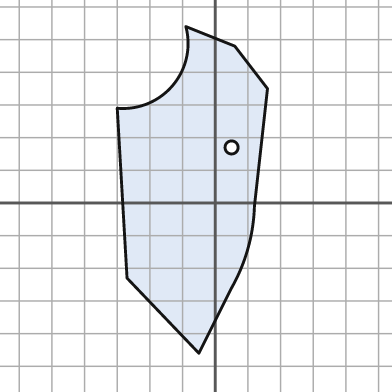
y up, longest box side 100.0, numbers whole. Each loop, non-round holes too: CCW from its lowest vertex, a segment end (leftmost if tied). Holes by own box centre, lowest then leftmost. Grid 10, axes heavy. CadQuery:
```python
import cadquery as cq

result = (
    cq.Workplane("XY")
    .moveTo(-5.0, -46.0)
    .lineTo(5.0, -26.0)
    .threePointArc((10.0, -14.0), (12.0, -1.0))
    .lineTo(16.0, 35.0)
    .lineTo(6.0, 48.0)
    .lineTo(-9.0, 54.0)
    .threePointArc((-13.0, 36.0), (-30.0, 29.0))
    .lineTo(-27.0, -23.0)
    .close()
    .moveTo(5.0, 17.0)
    .circle(2.0)
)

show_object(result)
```